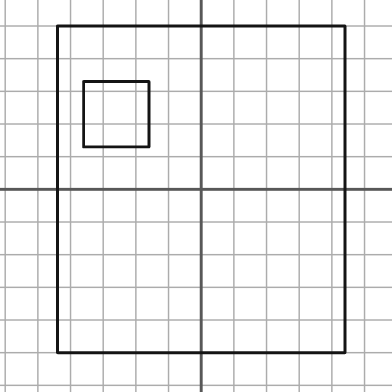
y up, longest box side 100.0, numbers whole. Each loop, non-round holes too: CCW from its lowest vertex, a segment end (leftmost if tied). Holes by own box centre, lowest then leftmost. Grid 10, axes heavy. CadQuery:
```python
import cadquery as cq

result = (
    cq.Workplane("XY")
    .moveTo(-44.0, -50.0)
    .lineTo(44.0, -50.0)
    .lineTo(44.0, 50.0)
    .lineTo(-44.0, 50.0)
    .close()
    .moveTo(-36.0, 13.0)
    .lineTo(-16.0, 13.0)
    .lineTo(-16.0, 33.0)
    .lineTo(-36.0, 33.0)
    .close()
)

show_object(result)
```